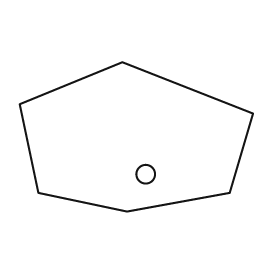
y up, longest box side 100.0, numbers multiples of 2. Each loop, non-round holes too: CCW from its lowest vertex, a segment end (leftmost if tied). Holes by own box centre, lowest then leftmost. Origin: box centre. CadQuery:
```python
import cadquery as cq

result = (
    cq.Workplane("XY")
    .moveTo(-4.0, -32.0)
    .lineTo(40.0, -24.0)
    .lineTo(50.0, 10.0)
    .lineTo(-6.0, 32.0)
    .lineTo(-50.0, 14.0)
    .lineTo(-42.0, -24.0)
    .close()
    .moveTo(4.0, -16.0)
    .circle(4.0)
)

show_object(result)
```